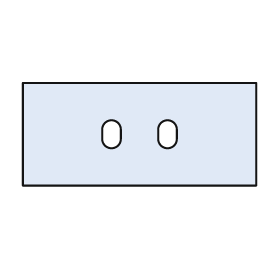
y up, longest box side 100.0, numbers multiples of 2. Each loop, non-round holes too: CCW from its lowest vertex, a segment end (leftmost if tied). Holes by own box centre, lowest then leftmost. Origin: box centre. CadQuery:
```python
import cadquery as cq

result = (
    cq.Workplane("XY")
    .moveTo(-50.0, -22.0)
    .lineTo(50.0, -22.0)
    .lineTo(50.0, 22.0)
    .lineTo(-50.0, 22.0)
    .close()
    .moveTo(-16.0, -2.0)
    .threePointArc((-12.0, -6.0), (-8.0, -2.0))
    .lineTo(-8.0, 2.0)
    .threePointArc((-12.0, 6.0), (-16.0, 2.0))
    .close()
    .moveTo(8.0, -2.0)
    .threePointArc((12.0, -6.0), (16.0, -2.0))
    .lineTo(16.0, 2.0)
    .threePointArc((12.0, 6.0), (8.0, 2.0))
    .close()
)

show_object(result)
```